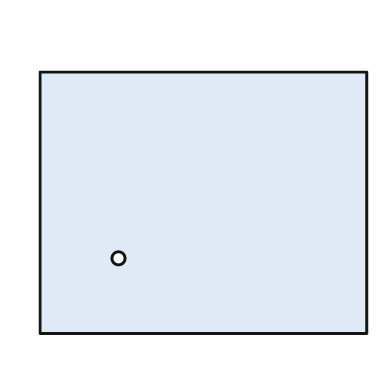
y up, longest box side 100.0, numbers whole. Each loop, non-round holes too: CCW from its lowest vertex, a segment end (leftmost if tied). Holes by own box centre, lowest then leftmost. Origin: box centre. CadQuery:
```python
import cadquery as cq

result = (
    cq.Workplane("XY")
    .moveTo(-50.0, -40.0)
    .lineTo(50.0, -40.0)
    .lineTo(50.0, 40.0)
    .lineTo(-50.0, 40.0)
    .close()
    .moveTo(-26.0, -17.0)
    .circle(2.0)
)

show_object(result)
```